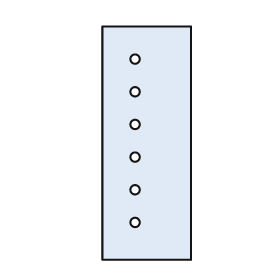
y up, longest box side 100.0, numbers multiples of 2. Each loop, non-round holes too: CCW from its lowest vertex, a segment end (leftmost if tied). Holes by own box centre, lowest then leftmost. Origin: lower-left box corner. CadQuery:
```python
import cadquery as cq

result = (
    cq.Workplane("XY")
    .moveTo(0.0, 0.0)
    .lineTo(38.0, 0.0)
    .lineTo(38.0, 100.0)
    .lineTo(0.0, 100.0)
    .close()
    .moveTo(14.0, 16.0)
    .circle(2.0)
    .moveTo(14.0, 30.0)
    .circle(2.0)
    .moveTo(14.0, 44.0)
    .circle(2.0)
    .moveTo(14.0, 58.0)
    .circle(2.0)
    .moveTo(14.0, 72.0)
    .circle(2.0)
    .moveTo(14.0, 86.0)
    .circle(2.0)
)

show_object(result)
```